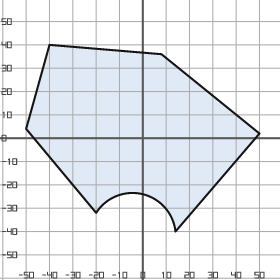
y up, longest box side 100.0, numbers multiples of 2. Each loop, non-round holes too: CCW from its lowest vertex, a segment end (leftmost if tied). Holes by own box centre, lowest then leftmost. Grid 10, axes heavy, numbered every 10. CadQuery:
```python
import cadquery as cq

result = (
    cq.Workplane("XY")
    .moveTo(14.0, -40.0)
    .lineTo(50.0, 2.0)
    .lineTo(8.0, 36.0)
    .lineTo(-40.0, 40.0)
    .lineTo(-50.0, 4.0)
    .lineTo(-20.0, -32.0)
    .threePointArc((0.0, -24.0), (14.0, -40.0))
    .close()
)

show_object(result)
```